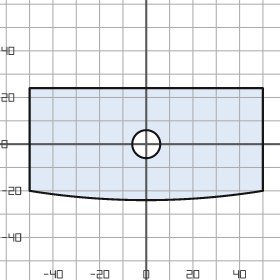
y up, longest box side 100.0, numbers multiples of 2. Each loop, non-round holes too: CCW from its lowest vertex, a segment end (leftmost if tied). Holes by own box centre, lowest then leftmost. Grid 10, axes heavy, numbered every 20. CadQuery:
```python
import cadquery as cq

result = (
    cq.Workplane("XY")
    .moveTo(-50.0, -20.0)
    .threePointArc((0.0, -24.0), (50.0, -20.0))
    .lineTo(50.0, 24.0)
    .lineTo(-50.0, 24.0)
    .close()
    .moveTo(0.0, 0.0)
    .circle(6.0)
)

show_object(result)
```